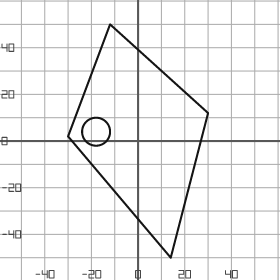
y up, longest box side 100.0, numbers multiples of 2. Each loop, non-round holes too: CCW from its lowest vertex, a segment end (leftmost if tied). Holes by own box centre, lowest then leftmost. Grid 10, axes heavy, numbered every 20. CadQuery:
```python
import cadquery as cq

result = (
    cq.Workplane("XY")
    .moveTo(14.0, -50.0)
    .lineTo(30.0, 12.0)
    .lineTo(-12.0, 50.0)
    .lineTo(-30.0, 2.0)
    .close()
    .moveTo(-18.0, 4.0)
    .circle(6.0)
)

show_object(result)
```